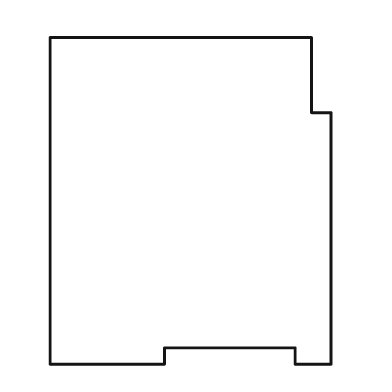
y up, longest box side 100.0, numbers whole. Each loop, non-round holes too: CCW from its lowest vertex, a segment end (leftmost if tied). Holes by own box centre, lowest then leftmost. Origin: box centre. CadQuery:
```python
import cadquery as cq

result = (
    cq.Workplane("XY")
    .moveTo(-43.0, -50.0)
    .lineTo(-8.0, -50.0)
    .lineTo(-8.0, -45.0)
    .lineTo(32.0, -45.0)
    .lineTo(32.0, -50.0)
    .lineTo(43.0, -50.0)
    .lineTo(43.0, 27.0)
    .lineTo(37.0, 27.0)
    .lineTo(37.0, 50.0)
    .lineTo(-43.0, 50.0)
    .close()
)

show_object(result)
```